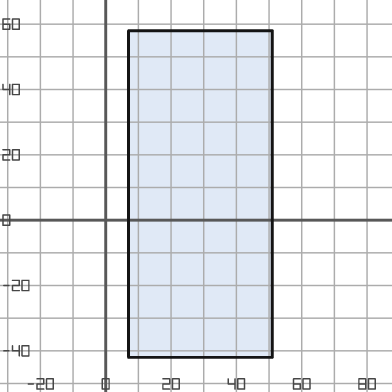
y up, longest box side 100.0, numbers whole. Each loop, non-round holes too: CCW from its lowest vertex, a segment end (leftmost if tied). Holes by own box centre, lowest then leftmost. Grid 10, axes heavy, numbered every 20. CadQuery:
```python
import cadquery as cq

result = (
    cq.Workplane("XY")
    .moveTo(7.0, -42.0)
    .lineTo(51.0, -42.0)
    .lineTo(51.0, 58.0)
    .lineTo(7.0, 58.0)
    .close()
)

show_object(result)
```